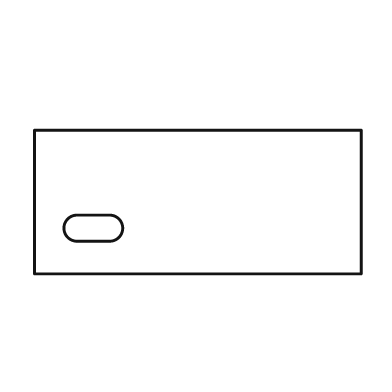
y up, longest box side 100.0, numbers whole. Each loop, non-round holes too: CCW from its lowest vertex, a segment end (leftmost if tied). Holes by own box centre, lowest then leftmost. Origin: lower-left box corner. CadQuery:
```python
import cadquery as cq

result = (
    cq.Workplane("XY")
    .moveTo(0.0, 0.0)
    .lineTo(100.0, 0.0)
    .lineTo(100.0, 44.0)
    .lineTo(0.0, 44.0)
    .close()
    .moveTo(13.0, 10.0)
    .lineTo(23.0, 10.0)
    .threePointArc((27.0, 14.0), (23.0, 18.0))
    .lineTo(13.0, 18.0)
    .threePointArc((9.0, 14.0), (13.0, 10.0))
    .close()
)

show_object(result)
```